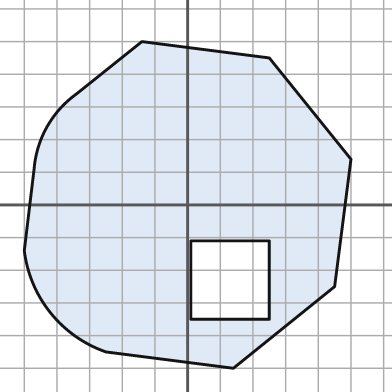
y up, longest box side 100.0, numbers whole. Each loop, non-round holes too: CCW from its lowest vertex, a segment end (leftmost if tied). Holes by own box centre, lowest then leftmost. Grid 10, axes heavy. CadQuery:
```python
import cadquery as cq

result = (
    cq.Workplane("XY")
    .moveTo(14.0, -50.0)
    .lineTo(45.0, -25.0)
    .lineTo(50.0, 14.0)
    .lineTo(25.0, 45.0)
    .lineTo(-14.0, 50.0)
    .lineTo(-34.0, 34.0)
    .threePointArc((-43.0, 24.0), (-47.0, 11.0))
    .lineTo(-50.0, -14.0)
    .threePointArc((-42.0, -33.0), (-25.0, -45.0))
    .close()
    .moveTo(1.0, -35.0)
    .lineTo(25.0, -35.0)
    .lineTo(25.0, -11.0)
    .lineTo(1.0, -11.0)
    .close()
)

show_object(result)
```